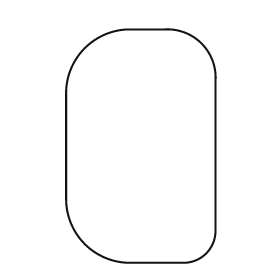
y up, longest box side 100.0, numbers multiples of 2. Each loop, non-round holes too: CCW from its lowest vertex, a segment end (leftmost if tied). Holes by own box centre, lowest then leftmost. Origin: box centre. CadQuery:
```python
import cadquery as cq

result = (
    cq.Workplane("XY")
    .moveTo(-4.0, -50.0)
    .lineTo(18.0, -50.0)
    .threePointArc((28.0, -46.0), (32.0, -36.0))
    .lineTo(32.0, 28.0)
    .threePointArc((26.0, 44.0), (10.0, 50.0))
    .lineTo(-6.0, 50.0)
    .threePointArc((-24.0, 42.0), (-32.0, 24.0))
    .lineTo(-32.0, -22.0)
    .threePointArc((-24.0, -42.0), (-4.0, -50.0))
    .close()
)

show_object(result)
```